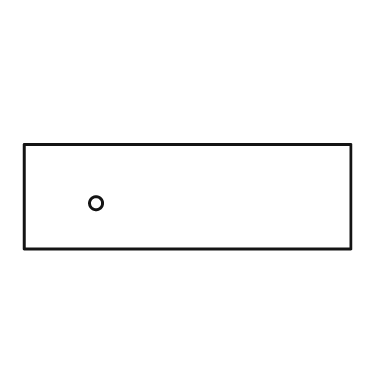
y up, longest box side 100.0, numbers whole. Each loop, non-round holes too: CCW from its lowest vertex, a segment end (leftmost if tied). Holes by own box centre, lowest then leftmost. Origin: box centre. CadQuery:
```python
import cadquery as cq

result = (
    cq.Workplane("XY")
    .moveTo(-50.0, -16.0)
    .lineTo(50.0, -16.0)
    .lineTo(50.0, 16.0)
    .lineTo(-50.0, 16.0)
    .close()
    .moveTo(-28.0, -2.0)
    .circle(2.0)
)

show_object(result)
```